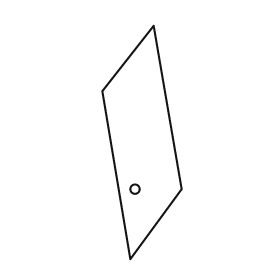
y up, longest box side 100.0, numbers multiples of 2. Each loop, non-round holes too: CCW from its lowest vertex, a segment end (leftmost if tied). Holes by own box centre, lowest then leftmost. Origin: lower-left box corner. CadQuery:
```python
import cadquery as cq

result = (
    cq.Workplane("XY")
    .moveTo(12.0, 0.0)
    .lineTo(34.0, 30.0)
    .lineTo(22.0, 100.0)
    .lineTo(0.0, 72.0)
    .close()
    .moveTo(14.0, 30.0)
    .circle(2.0)
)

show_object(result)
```